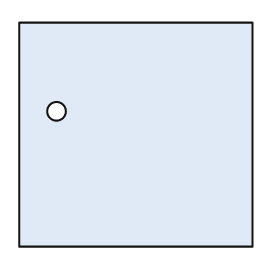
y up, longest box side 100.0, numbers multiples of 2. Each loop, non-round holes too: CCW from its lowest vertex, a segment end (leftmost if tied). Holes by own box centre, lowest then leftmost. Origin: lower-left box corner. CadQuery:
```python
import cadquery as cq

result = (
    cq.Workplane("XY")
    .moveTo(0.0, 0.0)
    .lineTo(100.0, 0.0)
    .lineTo(100.0, 96.0)
    .lineTo(0.0, 96.0)
    .close()
    .moveTo(16.0, 58.0)
    .circle(4.0)
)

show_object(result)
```